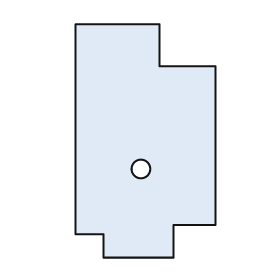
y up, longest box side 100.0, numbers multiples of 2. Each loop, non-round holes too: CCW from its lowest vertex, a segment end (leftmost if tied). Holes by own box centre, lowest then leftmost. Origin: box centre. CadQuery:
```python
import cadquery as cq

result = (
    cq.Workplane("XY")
    .moveTo(-18.0, -50.0)
    .lineTo(12.0, -50.0)
    .lineTo(12.0, -36.0)
    .lineTo(30.0, -36.0)
    .lineTo(30.0, 32.0)
    .lineTo(6.0, 32.0)
    .lineTo(6.0, 50.0)
    .lineTo(-30.0, 50.0)
    .lineTo(-30.0, -40.0)
    .lineTo(-18.0, -40.0)
    .close()
    .moveTo(-2.0, -12.0)
    .circle(4.0)
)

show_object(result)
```